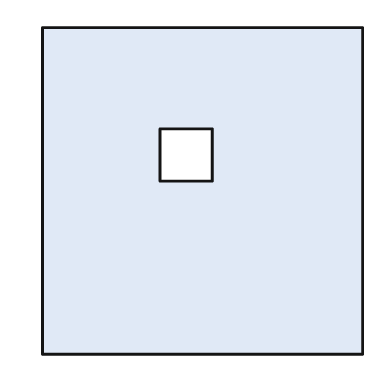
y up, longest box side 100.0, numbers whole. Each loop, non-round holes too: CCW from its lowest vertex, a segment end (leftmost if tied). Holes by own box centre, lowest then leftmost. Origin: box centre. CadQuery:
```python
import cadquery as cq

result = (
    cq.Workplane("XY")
    .moveTo(-49.0, -50.0)
    .lineTo(49.0, -50.0)
    .lineTo(49.0, 50.0)
    .lineTo(-49.0, 50.0)
    .close()
    .moveTo(-13.0, 3.0)
    .lineTo(3.0, 3.0)
    .lineTo(3.0, 19.0)
    .lineTo(-13.0, 19.0)
    .close()
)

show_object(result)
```